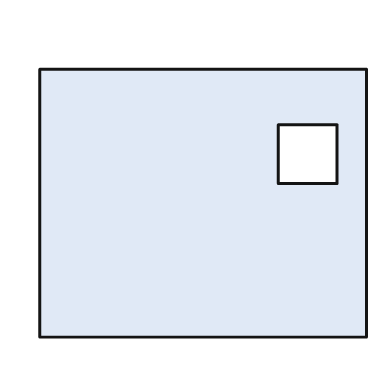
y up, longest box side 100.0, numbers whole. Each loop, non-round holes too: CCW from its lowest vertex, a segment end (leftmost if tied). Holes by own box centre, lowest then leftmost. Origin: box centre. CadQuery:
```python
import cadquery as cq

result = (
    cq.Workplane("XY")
    .moveTo(-50.0, -41.0)
    .lineTo(50.0, -41.0)
    .lineTo(50.0, 41.0)
    .lineTo(-50.0, 41.0)
    .close()
    .moveTo(23.0, 6.0)
    .lineTo(41.0, 6.0)
    .lineTo(41.0, 24.0)
    .lineTo(23.0, 24.0)
    .close()
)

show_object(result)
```